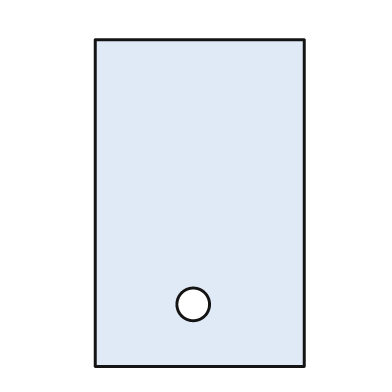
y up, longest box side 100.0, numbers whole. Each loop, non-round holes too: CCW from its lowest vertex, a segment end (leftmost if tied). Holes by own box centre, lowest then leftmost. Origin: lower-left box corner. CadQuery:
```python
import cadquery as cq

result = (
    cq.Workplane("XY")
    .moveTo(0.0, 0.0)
    .lineTo(64.0, 0.0)
    .lineTo(64.0, 100.0)
    .lineTo(0.0, 100.0)
    .close()
    .moveTo(30.0, 19.0)
    .circle(5.0)
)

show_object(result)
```